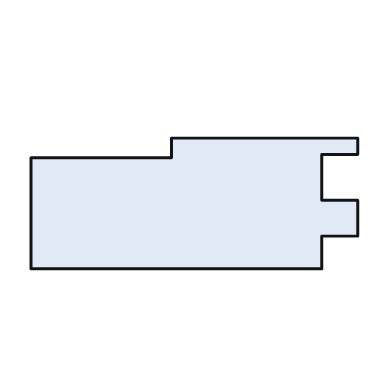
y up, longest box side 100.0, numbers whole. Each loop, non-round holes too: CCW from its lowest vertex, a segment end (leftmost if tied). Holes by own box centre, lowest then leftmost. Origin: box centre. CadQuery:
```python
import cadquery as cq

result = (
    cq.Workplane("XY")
    .moveTo(-50.0, -20.0)
    .lineTo(39.0, -20.0)
    .lineTo(39.0, -10.0)
    .lineTo(50.0, -10.0)
    .lineTo(50.0, 1.0)
    .lineTo(39.0, 1.0)
    .lineTo(39.0, 15.0)
    .lineTo(50.0, 15.0)
    .lineTo(50.0, 20.0)
    .lineTo(-7.0, 20.0)
    .lineTo(-7.0, 14.0)
    .lineTo(-50.0, 14.0)
    .close()
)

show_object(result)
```